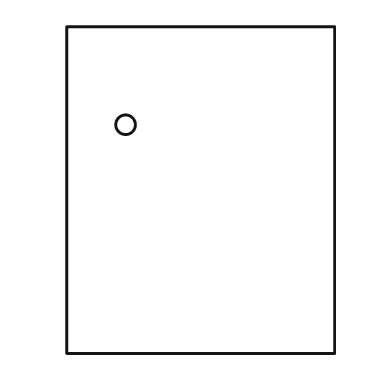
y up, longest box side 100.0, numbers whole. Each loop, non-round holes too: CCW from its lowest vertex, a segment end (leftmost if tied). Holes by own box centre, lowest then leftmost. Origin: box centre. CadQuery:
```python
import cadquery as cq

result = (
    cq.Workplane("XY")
    .moveTo(-41.0, -50.0)
    .lineTo(41.0, -50.0)
    .lineTo(41.0, 50.0)
    .lineTo(-41.0, 50.0)
    .close()
    .moveTo(-23.0, 20.0)
    .circle(3.0)
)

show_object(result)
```